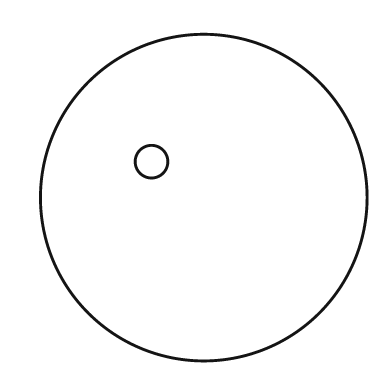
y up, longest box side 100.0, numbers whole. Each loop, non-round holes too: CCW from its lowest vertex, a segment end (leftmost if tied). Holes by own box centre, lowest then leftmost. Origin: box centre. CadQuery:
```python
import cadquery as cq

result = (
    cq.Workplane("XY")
    .moveTo(0.0, 0.0)
    .circle(50.0)
    .moveTo(-16.0, 11.0)
    .circle(5.0)
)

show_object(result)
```